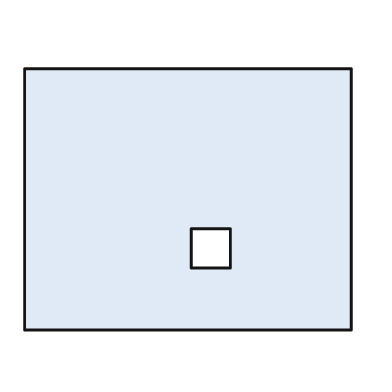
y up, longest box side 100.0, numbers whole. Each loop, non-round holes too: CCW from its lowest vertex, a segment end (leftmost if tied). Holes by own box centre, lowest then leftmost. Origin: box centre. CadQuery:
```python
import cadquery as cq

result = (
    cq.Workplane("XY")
    .moveTo(-50.0, -40.0)
    .lineTo(50.0, -40.0)
    .lineTo(50.0, 40.0)
    .lineTo(-50.0, 40.0)
    .close()
    .moveTo(1.0, -21.0)
    .lineTo(13.0, -21.0)
    .lineTo(13.0, -9.0)
    .lineTo(1.0, -9.0)
    .close()
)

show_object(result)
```